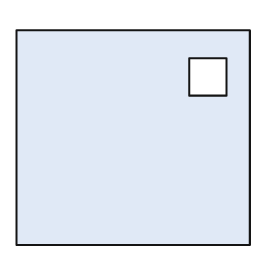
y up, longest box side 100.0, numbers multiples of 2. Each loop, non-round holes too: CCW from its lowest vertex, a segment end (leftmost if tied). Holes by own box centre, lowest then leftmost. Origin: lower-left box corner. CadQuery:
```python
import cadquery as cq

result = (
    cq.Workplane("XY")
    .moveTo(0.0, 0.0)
    .lineTo(100.0, 0.0)
    .lineTo(100.0, 92.0)
    .lineTo(0.0, 92.0)
    .close()
    .moveTo(74.0, 64.0)
    .lineTo(90.0, 64.0)
    .lineTo(90.0, 80.0)
    .lineTo(74.0, 80.0)
    .close()
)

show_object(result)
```